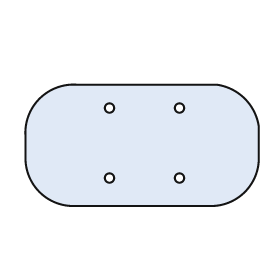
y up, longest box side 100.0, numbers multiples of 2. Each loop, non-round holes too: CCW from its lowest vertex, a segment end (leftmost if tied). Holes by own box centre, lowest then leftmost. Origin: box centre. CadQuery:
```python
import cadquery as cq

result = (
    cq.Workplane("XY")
    .moveTo(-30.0, -26.0)
    .lineTo(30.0, -26.0)
    .threePointArc((44.0, -20.0), (50.0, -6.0))
    .lineTo(50.0, 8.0)
    .threePointArc((44.0, 20.0), (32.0, 26.0))
    .lineTo(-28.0, 26.0)
    .threePointArc((-44.0, 20.0), (-50.0, 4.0))
    .lineTo(-50.0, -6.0)
    .threePointArc((-44.0, -20.0), (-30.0, -26.0))
    .close()
    .moveTo(-14.0, -14.0)
    .circle(2.0)
    .moveTo(16.0, -14.0)
    .circle(2.0)
    .moveTo(-14.0, 16.0)
    .circle(2.0)
    .moveTo(16.0, 16.0)
    .circle(2.0)
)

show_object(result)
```